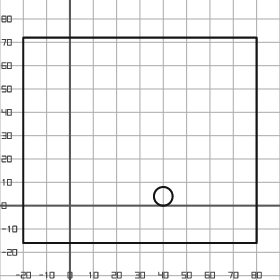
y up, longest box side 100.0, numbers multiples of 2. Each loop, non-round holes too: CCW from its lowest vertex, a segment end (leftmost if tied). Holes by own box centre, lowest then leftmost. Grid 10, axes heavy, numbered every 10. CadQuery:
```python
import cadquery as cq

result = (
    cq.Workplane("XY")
    .moveTo(-20.0, -16.0)
    .lineTo(80.0, -16.0)
    .lineTo(80.0, 72.0)
    .lineTo(-20.0, 72.0)
    .close()
    .moveTo(40.0, 4.0)
    .circle(4.0)
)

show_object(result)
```